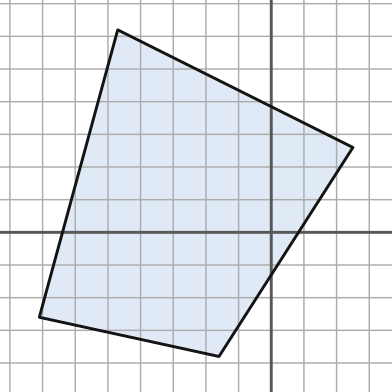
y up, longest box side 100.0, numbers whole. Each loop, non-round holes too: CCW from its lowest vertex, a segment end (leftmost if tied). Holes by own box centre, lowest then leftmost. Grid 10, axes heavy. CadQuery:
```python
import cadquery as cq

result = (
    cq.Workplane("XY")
    .moveTo(-16.0, -38.0)
    .lineTo(25.0, 26.0)
    .lineTo(-47.0, 62.0)
    .lineTo(-71.0, -26.0)
    .close()
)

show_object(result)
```